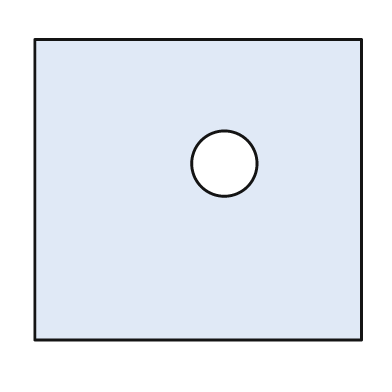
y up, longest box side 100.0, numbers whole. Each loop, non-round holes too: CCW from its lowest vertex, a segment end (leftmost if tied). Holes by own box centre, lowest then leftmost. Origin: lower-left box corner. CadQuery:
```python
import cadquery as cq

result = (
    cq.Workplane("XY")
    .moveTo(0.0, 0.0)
    .lineTo(100.0, 0.0)
    .lineTo(100.0, 92.0)
    .lineTo(0.0, 92.0)
    .close()
    .moveTo(58.0, 54.0)
    .circle(10.0)
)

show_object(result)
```